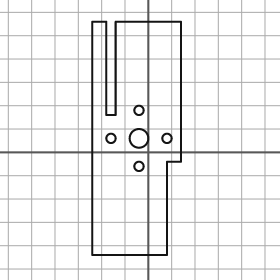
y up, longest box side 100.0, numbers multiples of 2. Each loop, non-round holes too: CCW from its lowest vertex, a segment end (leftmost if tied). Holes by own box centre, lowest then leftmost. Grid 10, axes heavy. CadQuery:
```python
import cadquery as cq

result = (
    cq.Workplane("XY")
    .moveTo(-24.0, -44.0)
    .lineTo(8.0, -44.0)
    .lineTo(8.0, -4.0)
    .lineTo(14.0, -4.0)
    .lineTo(14.0, 56.0)
    .lineTo(-14.0, 56.0)
    .lineTo(-14.0, 16.0)
    .lineTo(-18.0, 16.0)
    .lineTo(-18.0, 56.0)
    .lineTo(-24.0, 56.0)
    .close()
    .moveTo(-4.0, -6.0)
    .circle(2.0)
    .moveTo(-16.0, 6.0)
    .circle(2.0)
    .moveTo(-4.0, 6.0)
    .circle(4.0)
    .moveTo(8.0, 6.0)
    .circle(2.0)
    .moveTo(-4.0, 18.0)
    .circle(2.0)
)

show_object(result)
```